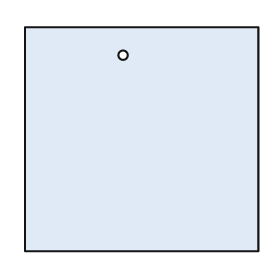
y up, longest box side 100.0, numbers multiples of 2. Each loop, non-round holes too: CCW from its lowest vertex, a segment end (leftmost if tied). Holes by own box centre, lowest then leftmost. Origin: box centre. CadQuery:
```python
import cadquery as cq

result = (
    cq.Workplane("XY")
    .moveTo(-50.0, -48.0)
    .lineTo(50.0, -48.0)
    .lineTo(50.0, 48.0)
    .lineTo(-50.0, 48.0)
    .close()
    .moveTo(-8.0, 36.0)
    .circle(2.0)
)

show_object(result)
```